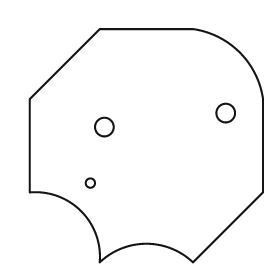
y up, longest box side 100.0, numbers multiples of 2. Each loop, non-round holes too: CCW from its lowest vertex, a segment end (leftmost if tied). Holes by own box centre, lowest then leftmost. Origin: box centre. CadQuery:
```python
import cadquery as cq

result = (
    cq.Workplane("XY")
    .moveTo(-20.0, -50.0)
    .threePointArc((0.0, -42.0), (20.0, -50.0))
    .lineTo(50.0, -20.0)
    .lineTo(50.0, 20.0)
    .threePointArc((40.0, 40.0), (20.0, 50.0))
    .lineTo(-20.0, 50.0)
    .lineTo(-50.0, 20.0)
    .lineTo(-50.0, -20.0)
    .threePointArc((-28.0, -28.0), (-20.0, -50.0))
    .close()
    .moveTo(-24.0, -16.0)
    .circle(2.0)
    .moveTo(-18.0, 8.0)
    .circle(4.0)
    .moveTo(34.0, 14.0)
    .circle(4.0)
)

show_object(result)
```